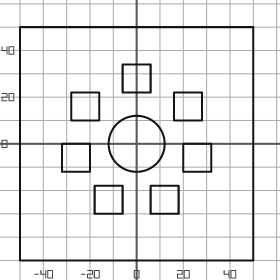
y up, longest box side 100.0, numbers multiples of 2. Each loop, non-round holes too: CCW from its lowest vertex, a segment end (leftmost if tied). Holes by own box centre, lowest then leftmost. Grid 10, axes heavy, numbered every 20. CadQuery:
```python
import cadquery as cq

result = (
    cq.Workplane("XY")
    .moveTo(-50.0, -50.0)
    .lineTo(50.0, -50.0)
    .lineTo(50.0, 50.0)
    .lineTo(-50.0, 50.0)
    .close()
    .moveTo(-18.0, -30.0)
    .lineTo(-6.0, -30.0)
    .lineTo(-6.0, -18.0)
    .lineTo(-18.0, -18.0)
    .close()
    .moveTo(6.0, -30.0)
    .lineTo(18.0, -30.0)
    .lineTo(18.0, -18.0)
    .lineTo(6.0, -18.0)
    .close()
    .moveTo(-32.0, -12.0)
    .lineTo(-20.0, -12.0)
    .lineTo(-20.0, 0.0)
    .lineTo(-32.0, 0.0)
    .close()
    .moveTo(20.0, -12.0)
    .lineTo(32.0, -12.0)
    .lineTo(32.0, 0.0)
    .lineTo(20.0, 0.0)
    .close()
    .moveTo(0.0, 0.0)
    .circle(12.0)
    .moveTo(-28.0, 10.0)
    .lineTo(-16.0, 10.0)
    .lineTo(-16.0, 22.0)
    .lineTo(-28.0, 22.0)
    .close()
    .moveTo(16.0, 10.0)
    .lineTo(28.0, 10.0)
    .lineTo(28.0, 22.0)
    .lineTo(16.0, 22.0)
    .close()
    .moveTo(-6.0, 22.0)
    .lineTo(6.0, 22.0)
    .lineTo(6.0, 34.0)
    .lineTo(-6.0, 34.0)
    .close()
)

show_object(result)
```